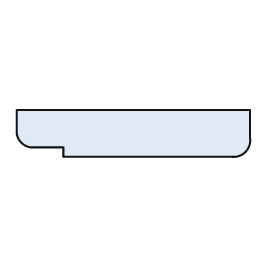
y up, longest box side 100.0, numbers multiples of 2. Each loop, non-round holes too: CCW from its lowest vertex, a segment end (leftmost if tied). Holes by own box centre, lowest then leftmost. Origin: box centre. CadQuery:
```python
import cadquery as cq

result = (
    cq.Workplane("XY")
    .moveTo(-30.0, -10.0)
    .lineTo(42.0, -10.0)
    .threePointArc((48.0, -8.0), (50.0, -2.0))
    .lineTo(50.0, 10.0)
    .lineTo(-50.0, 10.0)
    .lineTo(-50.0, 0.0)
    .threePointArc((-48.0, -4.0), (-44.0, -6.0))
    .lineTo(-30.0, -6.0)
    .close()
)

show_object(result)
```